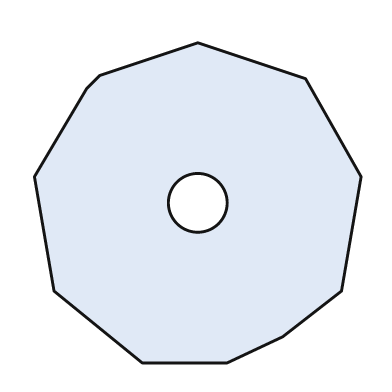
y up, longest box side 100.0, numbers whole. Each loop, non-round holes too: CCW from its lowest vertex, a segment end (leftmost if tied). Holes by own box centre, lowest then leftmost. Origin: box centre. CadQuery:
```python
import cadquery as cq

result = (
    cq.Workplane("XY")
    .moveTo(-17.0, -49.0)
    .lineTo(9.0, -49.0)
    .lineTo(26.0, -41.0)
    .lineTo(44.0, -27.0)
    .lineTo(50.0, 8.0)
    .lineTo(33.0, 38.0)
    .lineTo(0.0, 49.0)
    .lineTo(-30.0, 39.0)
    .lineTo(-34.0, 35.0)
    .lineTo(-50.0, 8.0)
    .lineTo(-44.0, -27.0)
    .close()
    .moveTo(0.0, 0.0)
    .circle(9.0)
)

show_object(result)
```